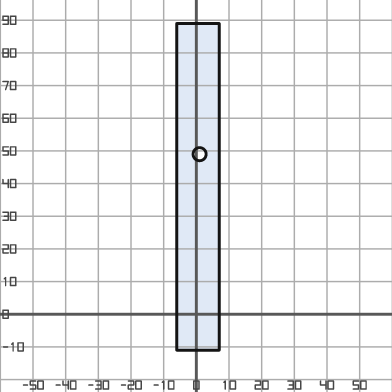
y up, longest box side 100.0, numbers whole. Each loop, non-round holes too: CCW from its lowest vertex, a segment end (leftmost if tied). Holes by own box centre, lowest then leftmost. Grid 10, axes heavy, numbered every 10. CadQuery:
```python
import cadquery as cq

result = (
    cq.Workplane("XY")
    .moveTo(-6.0, -11.0)
    .lineTo(7.0, -11.0)
    .lineTo(7.0, 89.0)
    .lineTo(-6.0, 89.0)
    .close()
    .moveTo(1.0, 49.0)
    .circle(2.0)
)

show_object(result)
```